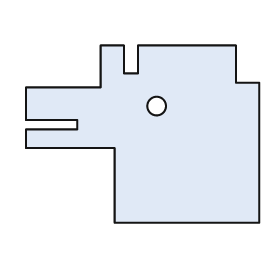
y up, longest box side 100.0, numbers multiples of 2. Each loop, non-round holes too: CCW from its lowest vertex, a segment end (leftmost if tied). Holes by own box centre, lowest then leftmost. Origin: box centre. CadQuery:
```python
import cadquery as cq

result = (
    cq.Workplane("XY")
    .moveTo(-12.0, -38.0)
    .lineTo(50.0, -38.0)
    .lineTo(50.0, 22.0)
    .lineTo(40.0, 22.0)
    .lineTo(40.0, 38.0)
    .lineTo(-2.0, 38.0)
    .lineTo(-2.0, 26.0)
    .lineTo(-8.0, 26.0)
    .lineTo(-8.0, 38.0)
    .lineTo(-18.0, 38.0)
    .lineTo(-18.0, 20.0)
    .lineTo(-50.0, 20.0)
    .lineTo(-50.0, 6.0)
    .lineTo(-28.0, 6.0)
    .lineTo(-28.0, 2.0)
    .lineTo(-50.0, 2.0)
    .lineTo(-50.0, -6.0)
    .lineTo(-12.0, -6.0)
    .close()
    .moveTo(6.0, 12.0)
    .circle(4.0)
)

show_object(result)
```